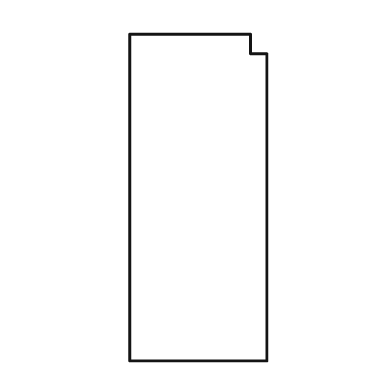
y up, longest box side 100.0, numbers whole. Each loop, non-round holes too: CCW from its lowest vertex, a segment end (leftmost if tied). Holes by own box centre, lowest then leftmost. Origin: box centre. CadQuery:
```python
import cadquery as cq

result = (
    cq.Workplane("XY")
    .moveTo(-21.0, -50.0)
    .lineTo(21.0, -50.0)
    .lineTo(21.0, 44.0)
    .lineTo(16.0, 44.0)
    .lineTo(16.0, 50.0)
    .lineTo(-21.0, 50.0)
    .close()
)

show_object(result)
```